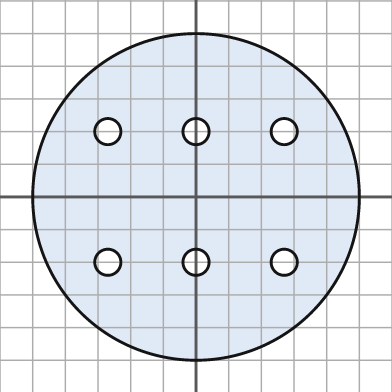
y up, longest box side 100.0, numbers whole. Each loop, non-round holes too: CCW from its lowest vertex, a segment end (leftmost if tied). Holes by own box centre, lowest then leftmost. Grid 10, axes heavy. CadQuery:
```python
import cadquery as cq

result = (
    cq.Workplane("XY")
    .moveTo(0.0, 0.0)
    .circle(50.0)
    .moveTo(-27.0, -20.0)
    .circle(4.0)
    .moveTo(0.0, -20.0)
    .circle(4.0)
    .moveTo(27.0, -20.0)
    .circle(4.0)
    .moveTo(-27.0, 20.0)
    .circle(4.0)
    .moveTo(0.0, 20.0)
    .circle(4.0)
    .moveTo(27.0, 20.0)
    .circle(4.0)
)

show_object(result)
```